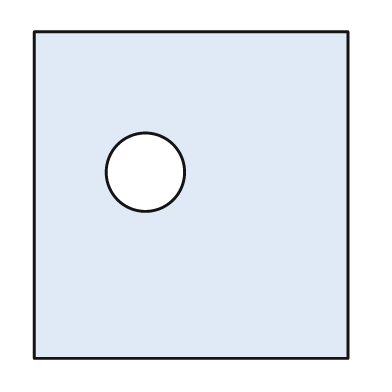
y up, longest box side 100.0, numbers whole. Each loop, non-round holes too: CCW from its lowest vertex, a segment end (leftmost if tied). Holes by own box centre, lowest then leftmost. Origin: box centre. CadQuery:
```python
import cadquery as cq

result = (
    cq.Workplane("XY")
    .moveTo(-48.0, -50.0)
    .lineTo(48.0, -50.0)
    .lineTo(48.0, 50.0)
    .lineTo(-48.0, 50.0)
    .close()
    .moveTo(-14.0, 7.0)
    .circle(12.0)
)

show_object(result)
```